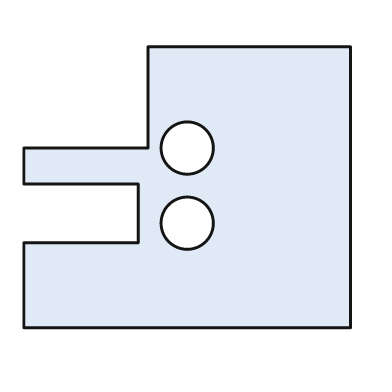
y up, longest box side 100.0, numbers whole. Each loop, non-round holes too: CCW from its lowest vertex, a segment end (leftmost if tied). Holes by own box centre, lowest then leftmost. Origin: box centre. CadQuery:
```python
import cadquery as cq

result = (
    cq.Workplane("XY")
    .moveTo(-50.0, -43.0)
    .lineTo(50.0, -43.0)
    .lineTo(50.0, 43.0)
    .lineTo(-12.0, 43.0)
    .lineTo(-12.0, 12.0)
    .lineTo(-50.0, 12.0)
    .lineTo(-50.0, 1.0)
    .lineTo(-15.0, 1.0)
    .lineTo(-15.0, -17.0)
    .lineTo(-50.0, -17.0)
    .close()
    .moveTo(0.0, -11.0)
    .circle(8.0)
    .moveTo(0.0, 12.0)
    .circle(8.0)
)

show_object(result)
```